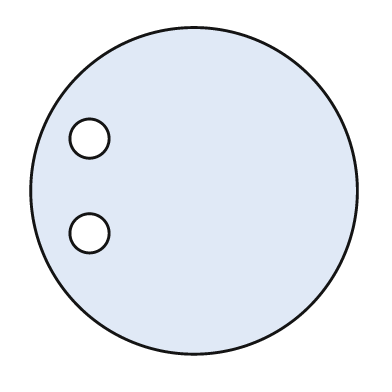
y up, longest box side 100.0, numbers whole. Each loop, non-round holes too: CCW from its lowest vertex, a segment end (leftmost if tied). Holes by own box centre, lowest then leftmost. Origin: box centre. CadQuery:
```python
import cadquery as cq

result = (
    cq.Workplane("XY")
    .moveTo(0.0, 0.0)
    .circle(50.0)
    .moveTo(-32.0, -13.0)
    .circle(6.0)
    .moveTo(-32.0, 16.0)
    .circle(6.0)
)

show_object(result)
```